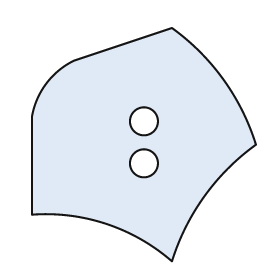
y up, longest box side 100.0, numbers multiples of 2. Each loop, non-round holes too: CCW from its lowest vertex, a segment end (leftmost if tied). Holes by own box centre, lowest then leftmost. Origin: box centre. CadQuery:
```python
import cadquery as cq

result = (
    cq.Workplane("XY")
    .moveTo(12.0, -50.0)
    .threePointArc((26.0, -22.0), (48.0, 0.0))
    .threePointArc((34.0, 28.0), (12.0, 50.0))
    .lineTo(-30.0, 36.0)
    .threePointArc((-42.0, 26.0), (-48.0, 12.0))
    .lineTo(-48.0, -30.0)
    .threePointArc((-16.0, -34.0), (12.0, -50.0))
    .close()
    .moveTo(0.0, -8.0)
    .circle(6.0)
    .moveTo(0.0, 10.0)
    .circle(6.0)
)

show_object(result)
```